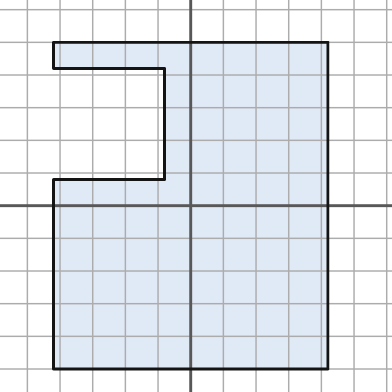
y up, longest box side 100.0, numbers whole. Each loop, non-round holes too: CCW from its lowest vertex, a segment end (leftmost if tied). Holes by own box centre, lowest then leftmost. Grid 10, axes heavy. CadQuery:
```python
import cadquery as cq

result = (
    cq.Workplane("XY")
    .moveTo(-42.0, -50.0)
    .lineTo(42.0, -50.0)
    .lineTo(42.0, 50.0)
    .lineTo(-42.0, 50.0)
    .lineTo(-42.0, 42.0)
    .lineTo(-8.0, 42.0)
    .lineTo(-8.0, 8.0)
    .lineTo(-42.0, 8.0)
    .close()
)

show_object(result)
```